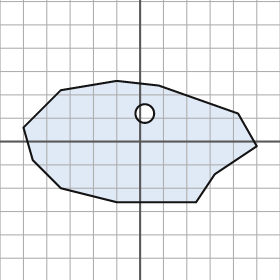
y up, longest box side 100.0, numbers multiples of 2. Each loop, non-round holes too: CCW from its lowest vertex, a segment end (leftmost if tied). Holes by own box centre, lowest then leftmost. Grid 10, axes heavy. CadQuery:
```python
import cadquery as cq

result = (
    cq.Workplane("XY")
    .moveTo(-10.0, -26.0)
    .lineTo(24.0, -26.0)
    .lineTo(32.0, -14.0)
    .lineTo(50.0, -2.0)
    .lineTo(42.0, 12.0)
    .lineTo(8.0, 24.0)
    .lineTo(-10.0, 26.0)
    .lineTo(-34.0, 22.0)
    .lineTo(-50.0, 6.0)
    .lineTo(-46.0, -8.0)
    .lineTo(-34.0, -20.0)
    .close()
    .moveTo(2.0, 12.0)
    .circle(4.0)
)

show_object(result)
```